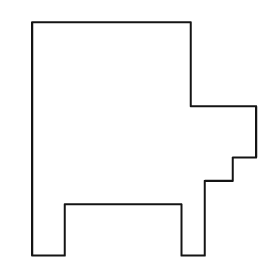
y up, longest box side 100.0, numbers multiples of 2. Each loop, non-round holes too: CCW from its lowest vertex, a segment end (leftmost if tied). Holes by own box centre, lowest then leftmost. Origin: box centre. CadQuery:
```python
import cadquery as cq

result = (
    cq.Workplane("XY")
    .moveTo(-48.0, -50.0)
    .lineTo(-34.0, -50.0)
    .lineTo(-34.0, -28.0)
    .lineTo(16.0, -28.0)
    .lineTo(16.0, -50.0)
    .lineTo(26.0, -50.0)
    .lineTo(26.0, -18.0)
    .lineTo(38.0, -18.0)
    .lineTo(38.0, -8.0)
    .lineTo(48.0, -8.0)
    .lineTo(48.0, 14.0)
    .lineTo(20.0, 14.0)
    .lineTo(20.0, 50.0)
    .lineTo(-48.0, 50.0)
    .close()
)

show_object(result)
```